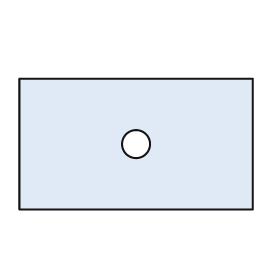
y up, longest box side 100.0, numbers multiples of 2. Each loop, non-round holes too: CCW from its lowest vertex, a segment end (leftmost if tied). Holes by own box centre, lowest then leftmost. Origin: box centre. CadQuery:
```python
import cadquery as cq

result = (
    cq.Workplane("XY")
    .moveTo(-50.0, -28.0)
    .lineTo(50.0, -28.0)
    .lineTo(50.0, 28.0)
    .lineTo(-50.0, 28.0)
    .close()
    .moveTo(0.0, 0.0)
    .circle(6.0)
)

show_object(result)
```